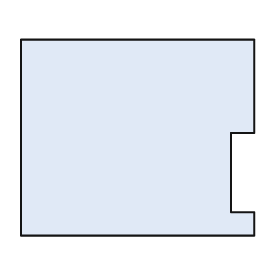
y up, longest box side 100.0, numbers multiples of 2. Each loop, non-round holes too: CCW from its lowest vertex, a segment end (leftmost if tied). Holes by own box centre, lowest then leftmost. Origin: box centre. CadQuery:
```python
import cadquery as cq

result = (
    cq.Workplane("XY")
    .moveTo(-50.0, -42.0)
    .lineTo(50.0, -42.0)
    .lineTo(50.0, -32.0)
    .lineTo(40.0, -32.0)
    .lineTo(40.0, 2.0)
    .lineTo(50.0, 2.0)
    .lineTo(50.0, 42.0)
    .lineTo(-50.0, 42.0)
    .close()
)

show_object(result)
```